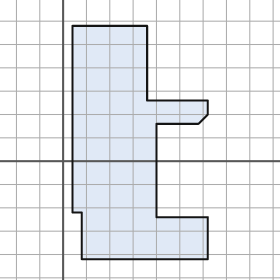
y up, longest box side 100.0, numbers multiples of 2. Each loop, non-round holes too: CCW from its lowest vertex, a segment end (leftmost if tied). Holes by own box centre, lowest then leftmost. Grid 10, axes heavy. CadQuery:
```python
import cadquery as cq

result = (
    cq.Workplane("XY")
    .moveTo(8.0, -42.0)
    .lineTo(62.0, -42.0)
    .lineTo(62.0, -24.0)
    .lineTo(40.0, -24.0)
    .lineTo(40.0, 16.0)
    .lineTo(58.0, 16.0)
    .lineTo(62.0, 20.0)
    .lineTo(62.0, 26.0)
    .lineTo(36.0, 26.0)
    .lineTo(36.0, 58.0)
    .lineTo(4.0, 58.0)
    .lineTo(4.0, -22.0)
    .lineTo(8.0, -22.0)
    .close()
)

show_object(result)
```